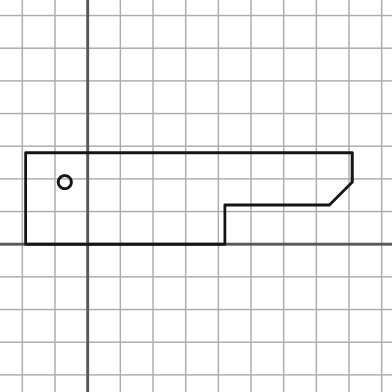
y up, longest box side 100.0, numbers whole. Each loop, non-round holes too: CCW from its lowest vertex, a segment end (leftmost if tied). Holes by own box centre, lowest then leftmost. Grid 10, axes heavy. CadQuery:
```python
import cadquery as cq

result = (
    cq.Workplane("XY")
    .moveTo(-19.0, 0.0)
    .lineTo(42.0, 0.0)
    .lineTo(42.0, 12.0)
    .lineTo(74.0, 12.0)
    .lineTo(81.0, 19.0)
    .lineTo(81.0, 28.0)
    .lineTo(-19.0, 28.0)
    .close()
    .moveTo(-7.0, 19.0)
    .circle(2.0)
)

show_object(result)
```